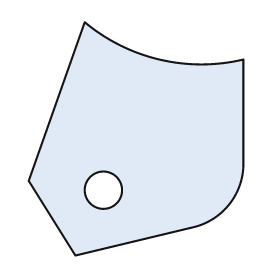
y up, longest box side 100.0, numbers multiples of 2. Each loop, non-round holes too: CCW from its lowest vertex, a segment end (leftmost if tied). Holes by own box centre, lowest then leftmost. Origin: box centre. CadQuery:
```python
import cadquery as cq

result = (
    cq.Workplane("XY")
    .moveTo(-26.0, -50.0)
    .lineTo(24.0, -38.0)
    .threePointArc((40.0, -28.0), (46.0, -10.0))
    .lineTo(46.0, 34.0)
    .threePointArc((10.0, 34.0), (-22.0, 50.0))
    .lineTo(-46.0, -18.0)
    .close()
    .moveTo(-14.0, -22.0)
    .circle(8.0)
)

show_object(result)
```